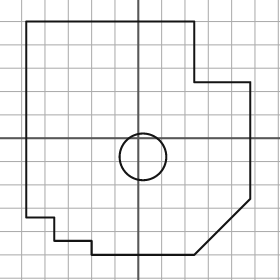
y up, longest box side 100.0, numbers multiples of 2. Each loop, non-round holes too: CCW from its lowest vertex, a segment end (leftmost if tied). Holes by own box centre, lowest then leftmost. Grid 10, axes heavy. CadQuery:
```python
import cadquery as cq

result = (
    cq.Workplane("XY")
    .moveTo(-20.0, -50.0)
    .lineTo(24.0, -50.0)
    .lineTo(48.0, -26.0)
    .lineTo(48.0, 24.0)
    .lineTo(24.0, 24.0)
    .lineTo(24.0, 50.0)
    .lineTo(-48.0, 50.0)
    .lineTo(-48.0, -34.0)
    .lineTo(-36.0, -34.0)
    .lineTo(-36.0, -44.0)
    .lineTo(-20.0, -44.0)
    .close()
    .moveTo(2.0, -8.0)
    .circle(10.0)
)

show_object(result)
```